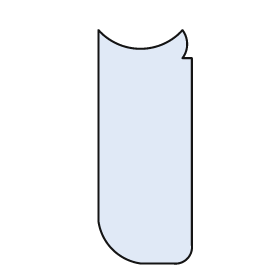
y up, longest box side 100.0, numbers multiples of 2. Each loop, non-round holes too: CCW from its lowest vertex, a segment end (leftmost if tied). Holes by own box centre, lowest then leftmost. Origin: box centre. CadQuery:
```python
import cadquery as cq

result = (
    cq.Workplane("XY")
    .moveTo(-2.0, -50.0)
    .lineTo(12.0, -50.0)
    .threePointArc((18.0, -48.0), (20.0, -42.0))
    .lineTo(20.0, 38.0)
    .lineTo(16.0, 38.0)
    .threePointArc((18.0, 44.0), (16.0, 50.0))
    .threePointArc((-2.0, 42.0), (-20.0, 50.0))
    .lineTo(-20.0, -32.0)
    .threePointArc((-14.0, -44.0), (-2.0, -50.0))
    .close()
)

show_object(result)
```